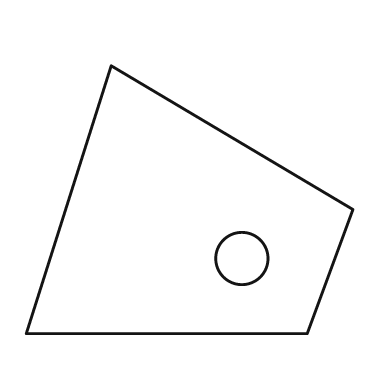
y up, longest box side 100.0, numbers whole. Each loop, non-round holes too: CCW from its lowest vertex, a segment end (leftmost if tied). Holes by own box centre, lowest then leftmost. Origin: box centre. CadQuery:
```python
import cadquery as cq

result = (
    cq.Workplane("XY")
    .moveTo(-50.0, -41.0)
    .lineTo(36.0, -41.0)
    .lineTo(50.0, -3.0)
    .lineTo(-24.0, 41.0)
    .close()
    .moveTo(16.0, -18.0)
    .circle(8.0)
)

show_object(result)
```